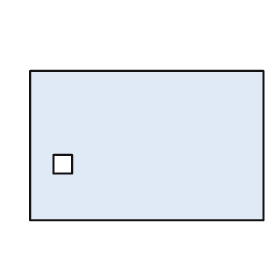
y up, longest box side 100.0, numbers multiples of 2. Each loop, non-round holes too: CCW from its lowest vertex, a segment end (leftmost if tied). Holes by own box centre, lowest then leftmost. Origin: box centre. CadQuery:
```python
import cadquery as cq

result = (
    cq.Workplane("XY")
    .moveTo(-50.0, -32.0)
    .lineTo(50.0, -32.0)
    .lineTo(50.0, 32.0)
    .lineTo(-50.0, 32.0)
    .close()
    .moveTo(-40.0, -12.0)
    .lineTo(-32.0, -12.0)
    .lineTo(-32.0, -4.0)
    .lineTo(-40.0, -4.0)
    .close()
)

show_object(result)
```